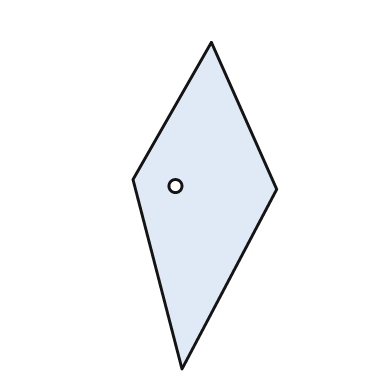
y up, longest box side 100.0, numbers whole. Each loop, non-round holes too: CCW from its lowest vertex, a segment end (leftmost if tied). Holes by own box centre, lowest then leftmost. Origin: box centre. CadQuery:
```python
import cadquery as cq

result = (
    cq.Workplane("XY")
    .moveTo(-7.0, -50.0)
    .lineTo(22.0, 5.0)
    .lineTo(2.0, 50.0)
    .lineTo(-22.0, 8.0)
    .close()
    .moveTo(-9.0, 6.0)
    .circle(2.0)
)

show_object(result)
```